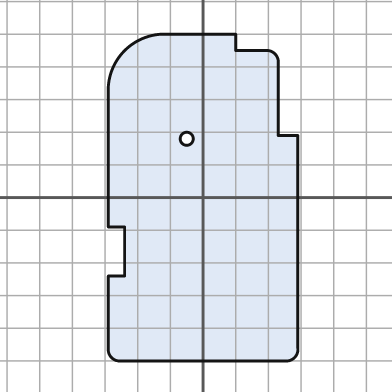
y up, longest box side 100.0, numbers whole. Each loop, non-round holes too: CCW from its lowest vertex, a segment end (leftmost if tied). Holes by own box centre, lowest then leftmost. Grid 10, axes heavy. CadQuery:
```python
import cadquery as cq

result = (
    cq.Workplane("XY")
    .moveTo(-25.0, -50.0)
    .lineTo(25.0, -50.0)
    .threePointArc((28.0, -49.0), (29.0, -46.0))
    .lineTo(29.0, 19.0)
    .lineTo(23.0, 19.0)
    .lineTo(23.0, 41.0)
    .threePointArc((22.0, 44.0), (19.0, 45.0))
    .lineTo(10.0, 45.0)
    .lineTo(10.0, 50.0)
    .lineTo(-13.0, 50.0)
    .threePointArc((-24.0, 45.0), (-29.0, 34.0))
    .lineTo(-29.0, -9.0)
    .lineTo(-24.0, -9.0)
    .lineTo(-24.0, -24.0)
    .lineTo(-29.0, -24.0)
    .lineTo(-29.0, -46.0)
    .threePointArc((-28.0, -49.0), (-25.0, -50.0))
    .close()
    .moveTo(-5.0, 18.0)
    .circle(2.0)
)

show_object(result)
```